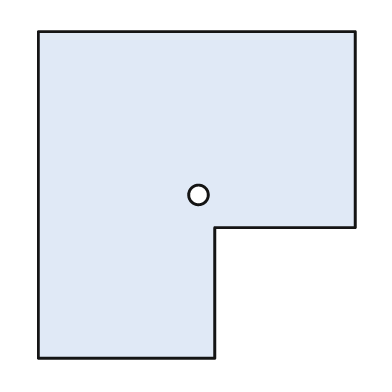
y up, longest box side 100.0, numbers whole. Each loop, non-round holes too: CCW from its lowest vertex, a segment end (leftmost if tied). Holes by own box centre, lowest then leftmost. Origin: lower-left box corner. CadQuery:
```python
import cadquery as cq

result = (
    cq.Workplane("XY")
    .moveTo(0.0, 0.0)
    .lineTo(54.0, 0.0)
    .lineTo(54.0, 40.0)
    .lineTo(97.0, 40.0)
    .lineTo(97.0, 100.0)
    .lineTo(0.0, 100.0)
    .close()
    .moveTo(49.0, 50.0)
    .circle(3.0)
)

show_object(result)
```